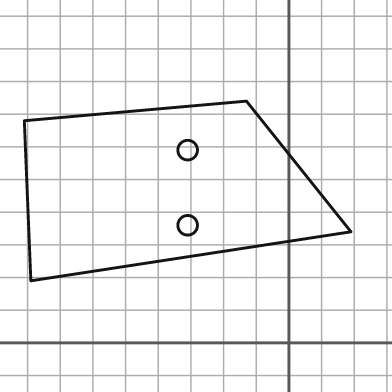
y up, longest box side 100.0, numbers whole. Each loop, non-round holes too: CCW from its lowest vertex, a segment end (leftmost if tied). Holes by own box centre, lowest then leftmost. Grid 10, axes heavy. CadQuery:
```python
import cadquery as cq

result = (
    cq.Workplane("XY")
    .moveTo(-79.0, 19.0)
    .lineTo(19.0, 34.0)
    .lineTo(-13.0, 74.0)
    .lineTo(-81.0, 68.0)
    .close()
    .moveTo(-31.0, 36.0)
    .circle(3.0)
    .moveTo(-31.0, 59.0)
    .circle(3.0)
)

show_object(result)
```